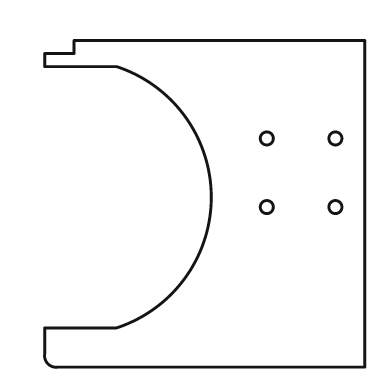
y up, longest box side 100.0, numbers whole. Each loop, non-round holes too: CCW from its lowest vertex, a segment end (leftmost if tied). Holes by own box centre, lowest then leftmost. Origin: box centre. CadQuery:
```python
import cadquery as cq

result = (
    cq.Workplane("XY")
    .moveTo(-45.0, -50.0)
    .lineTo(49.0, -50.0)
    .lineTo(49.0, 50.0)
    .lineTo(-40.0, 50.0)
    .lineTo(-40.0, 46.0)
    .lineTo(-49.0, 46.0)
    .lineTo(-49.0, 42.0)
    .lineTo(-27.0, 42.0)
    .threePointArc((2.0, 2.0), (-27.0, -38.0))
    .lineTo(-49.0, -38.0)
    .lineTo(-49.0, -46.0)
    .threePointArc((-48.0, -49.0), (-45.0, -50.0))
    .close()
    .moveTo(19.0, -1.0)
    .circle(2.0)
    .moveTo(40.0, -1.0)
    .circle(2.0)
    .moveTo(19.0, 20.0)
    .circle(2.0)
    .moveTo(40.0, 20.0)
    .circle(2.0)
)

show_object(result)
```